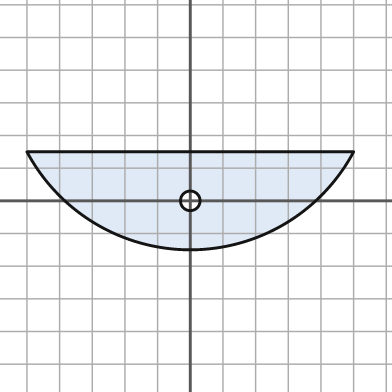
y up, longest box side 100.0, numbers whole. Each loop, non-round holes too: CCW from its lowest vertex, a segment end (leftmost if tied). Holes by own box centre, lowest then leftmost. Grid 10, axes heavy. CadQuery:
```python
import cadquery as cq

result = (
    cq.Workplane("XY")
    .moveTo(-50.0, 15.0)
    .threePointArc((0.0, -15.0), (50.0, 15.0))
    .close()
    .moveTo(0.0, 0.0)
    .circle(3.0)
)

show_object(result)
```